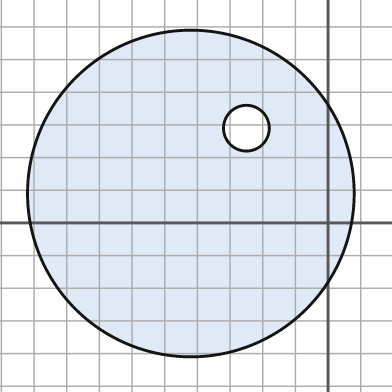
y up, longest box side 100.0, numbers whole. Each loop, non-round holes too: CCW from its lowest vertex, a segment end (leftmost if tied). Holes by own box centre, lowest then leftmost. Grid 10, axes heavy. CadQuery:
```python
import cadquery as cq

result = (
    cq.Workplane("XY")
    .moveTo(-42.0, 9.0)
    .circle(50.0)
    .moveTo(-25.0, 29.0)
    .circle(7.0)
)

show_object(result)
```